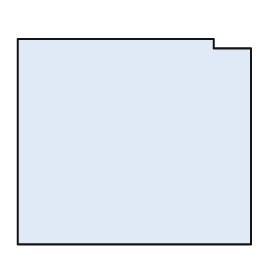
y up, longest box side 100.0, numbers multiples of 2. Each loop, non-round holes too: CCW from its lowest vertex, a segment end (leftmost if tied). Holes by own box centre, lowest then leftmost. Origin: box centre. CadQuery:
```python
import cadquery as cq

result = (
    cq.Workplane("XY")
    .moveTo(-50.0, -44.0)
    .lineTo(50.0, -44.0)
    .lineTo(50.0, 40.0)
    .lineTo(34.0, 40.0)
    .lineTo(34.0, 44.0)
    .lineTo(-50.0, 44.0)
    .close()
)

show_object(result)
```